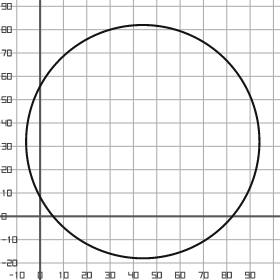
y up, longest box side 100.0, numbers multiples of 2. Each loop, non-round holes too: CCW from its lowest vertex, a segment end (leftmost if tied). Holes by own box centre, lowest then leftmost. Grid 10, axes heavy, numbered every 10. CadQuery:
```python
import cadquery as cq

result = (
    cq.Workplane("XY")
    .moveTo(44.0, 32.0)
    .circle(50.0)
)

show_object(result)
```